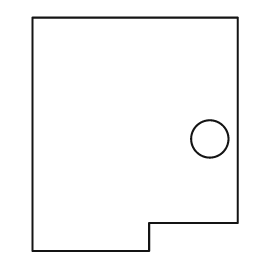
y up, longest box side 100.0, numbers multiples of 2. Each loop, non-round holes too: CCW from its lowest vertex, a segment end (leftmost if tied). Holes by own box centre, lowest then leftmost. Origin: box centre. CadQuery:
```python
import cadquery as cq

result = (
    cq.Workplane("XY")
    .moveTo(-44.0, -50.0)
    .lineTo(6.0, -50.0)
    .lineTo(6.0, -38.0)
    .lineTo(44.0, -38.0)
    .lineTo(44.0, 50.0)
    .lineTo(-44.0, 50.0)
    .close()
    .moveTo(32.0, -2.0)
    .circle(8.0)
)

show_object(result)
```